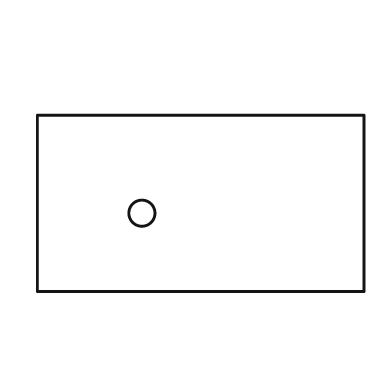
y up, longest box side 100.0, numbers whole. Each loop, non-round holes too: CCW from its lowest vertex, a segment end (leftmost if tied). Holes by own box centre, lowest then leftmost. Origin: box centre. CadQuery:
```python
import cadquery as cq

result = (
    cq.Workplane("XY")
    .moveTo(-50.0, -27.0)
    .lineTo(50.0, -27.0)
    .lineTo(50.0, 27.0)
    .lineTo(-50.0, 27.0)
    .close()
    .moveTo(-18.0, -3.0)
    .circle(4.0)
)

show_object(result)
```